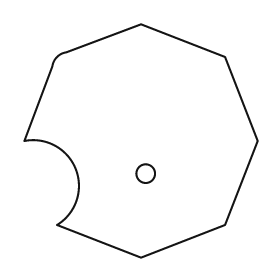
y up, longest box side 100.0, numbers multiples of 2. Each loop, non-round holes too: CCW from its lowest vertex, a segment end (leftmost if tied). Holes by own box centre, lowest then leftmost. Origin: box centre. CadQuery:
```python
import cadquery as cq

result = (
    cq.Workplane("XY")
    .moveTo(0.0, -50.0)
    .lineTo(36.0, -36.0)
    .lineTo(50.0, 0.0)
    .lineTo(36.0, 36.0)
    .lineTo(0.0, 50.0)
    .lineTo(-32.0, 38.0)
    .threePointArc((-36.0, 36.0), (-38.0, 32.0))
    .lineTo(-50.0, 0.0)
    .threePointArc((-28.0, -12.0), (-36.0, -36.0))
    .close()
    .moveTo(2.0, -14.0)
    .circle(4.0)
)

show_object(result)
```